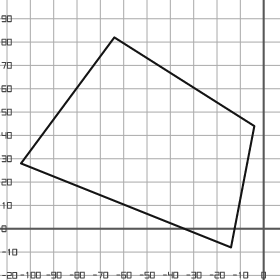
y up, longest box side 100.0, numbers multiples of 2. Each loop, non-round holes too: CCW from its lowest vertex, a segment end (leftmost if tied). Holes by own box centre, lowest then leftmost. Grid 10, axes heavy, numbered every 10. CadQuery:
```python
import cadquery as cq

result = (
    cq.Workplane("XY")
    .moveTo(-14.0, -8.0)
    .lineTo(-4.0, 44.0)
    .lineTo(-64.0, 82.0)
    .lineTo(-104.0, 28.0)
    .close()
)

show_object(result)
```